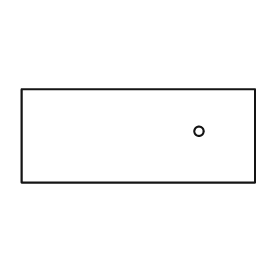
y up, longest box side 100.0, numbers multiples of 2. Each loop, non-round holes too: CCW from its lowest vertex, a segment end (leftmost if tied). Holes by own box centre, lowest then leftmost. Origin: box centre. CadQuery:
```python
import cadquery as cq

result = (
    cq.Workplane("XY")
    .moveTo(-50.0, -20.0)
    .lineTo(50.0, -20.0)
    .lineTo(50.0, 20.0)
    .lineTo(-50.0, 20.0)
    .close()
    .moveTo(26.0, 2.0)
    .circle(2.0)
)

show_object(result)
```